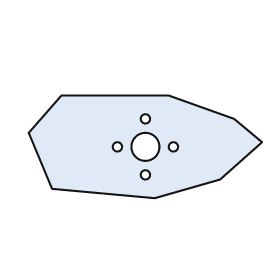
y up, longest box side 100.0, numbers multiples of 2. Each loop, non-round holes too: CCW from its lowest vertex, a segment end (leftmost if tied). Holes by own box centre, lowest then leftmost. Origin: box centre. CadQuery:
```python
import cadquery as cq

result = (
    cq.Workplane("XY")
    .moveTo(4.0, -22.0)
    .lineTo(32.0, -14.0)
    .lineTo(50.0, 2.0)
    .lineTo(38.0, 12.0)
    .lineTo(10.0, 22.0)
    .lineTo(-36.0, 22.0)
    .lineTo(-50.0, 6.0)
    .lineTo(-40.0, -18.0)
    .close()
    .moveTo(0.0, -12.0)
    .circle(2.0)
    .moveTo(-12.0, 0.0)
    .circle(2.0)
    .moveTo(0.0, 0.0)
    .circle(6.0)
    .moveTo(12.0, 0.0)
    .circle(2.0)
    .moveTo(0.0, 12.0)
    .circle(2.0)
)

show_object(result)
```